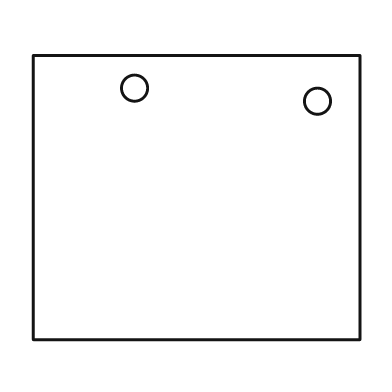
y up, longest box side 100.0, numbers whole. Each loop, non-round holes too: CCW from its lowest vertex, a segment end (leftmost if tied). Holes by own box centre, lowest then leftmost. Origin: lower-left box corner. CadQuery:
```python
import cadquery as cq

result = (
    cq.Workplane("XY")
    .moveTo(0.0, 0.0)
    .lineTo(100.0, 0.0)
    .lineTo(100.0, 87.0)
    .lineTo(0.0, 87.0)
    .close()
    .moveTo(87.0, 73.0)
    .circle(4.0)
    .moveTo(31.0, 77.0)
    .circle(4.0)
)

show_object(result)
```